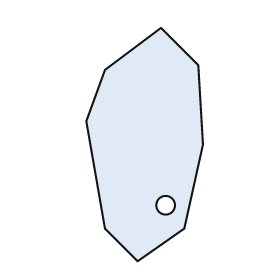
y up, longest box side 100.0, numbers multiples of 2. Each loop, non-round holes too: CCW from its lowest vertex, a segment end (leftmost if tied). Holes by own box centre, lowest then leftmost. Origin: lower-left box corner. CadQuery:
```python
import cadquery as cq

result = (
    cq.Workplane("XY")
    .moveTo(22.0, 0.0)
    .lineTo(42.0, 14.0)
    .lineTo(50.0, 50.0)
    .lineTo(48.0, 84.0)
    .lineTo(32.0, 100.0)
    .lineTo(8.0, 82.0)
    .lineTo(0.0, 60.0)
    .lineTo(8.0, 14.0)
    .close()
    .moveTo(34.0, 24.0)
    .circle(4.0)
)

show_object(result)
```